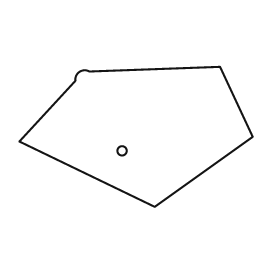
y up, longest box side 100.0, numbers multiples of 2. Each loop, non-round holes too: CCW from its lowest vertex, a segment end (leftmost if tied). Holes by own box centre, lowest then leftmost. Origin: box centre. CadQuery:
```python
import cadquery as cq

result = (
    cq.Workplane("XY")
    .moveTo(8.0, -30.0)
    .lineTo(50.0, 0.0)
    .lineTo(36.0, 30.0)
    .lineTo(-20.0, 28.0)
    .threePointArc((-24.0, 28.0), (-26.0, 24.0))
    .lineTo(-50.0, -2.0)
    .close()
    .moveTo(-6.0, -6.0)
    .circle(2.0)
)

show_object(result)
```